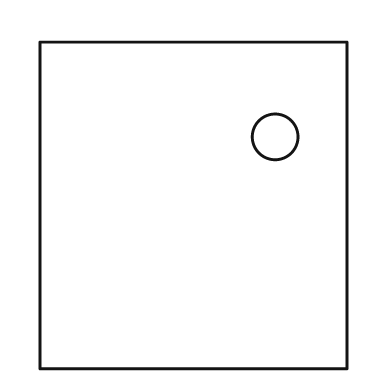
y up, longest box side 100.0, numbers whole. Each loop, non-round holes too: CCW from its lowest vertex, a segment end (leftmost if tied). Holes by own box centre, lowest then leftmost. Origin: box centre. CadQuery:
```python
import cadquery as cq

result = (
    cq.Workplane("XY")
    .moveTo(-47.0, -50.0)
    .lineTo(47.0, -50.0)
    .lineTo(47.0, 50.0)
    .lineTo(-47.0, 50.0)
    .close()
    .moveTo(25.0, 21.0)
    .circle(7.0)
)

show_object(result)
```